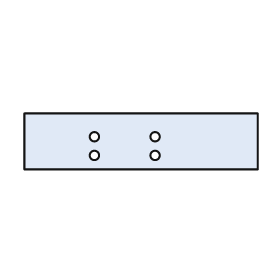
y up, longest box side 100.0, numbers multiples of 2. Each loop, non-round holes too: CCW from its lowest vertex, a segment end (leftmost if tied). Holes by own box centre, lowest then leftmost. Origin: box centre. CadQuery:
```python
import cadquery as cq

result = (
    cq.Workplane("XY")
    .moveTo(-50.0, -12.0)
    .lineTo(50.0, -12.0)
    .lineTo(50.0, 12.0)
    .lineTo(-50.0, 12.0)
    .close()
    .moveTo(-20.0, -6.0)
    .circle(2.0)
    .moveTo(6.0, -6.0)
    .circle(2.0)
    .moveTo(-20.0, 2.0)
    .circle(2.0)
    .moveTo(6.0, 2.0)
    .circle(2.0)
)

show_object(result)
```